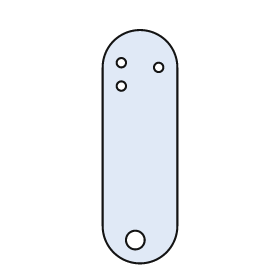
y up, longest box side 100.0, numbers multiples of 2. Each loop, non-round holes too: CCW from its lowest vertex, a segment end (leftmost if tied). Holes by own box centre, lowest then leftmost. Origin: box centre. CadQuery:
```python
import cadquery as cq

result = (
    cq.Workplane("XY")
    .moveTo(-16.0, -34.0)
    .threePointArc((0.0, -50.0), (16.0, -34.0))
    .lineTo(16.0, 34.0)
    .threePointArc((0.0, 50.0), (-16.0, 34.0))
    .close()
    .moveTo(-2.0, -40.0)
    .circle(4.0)
    .moveTo(-8.0, 26.0)
    .circle(2.0)
    .moveTo(8.0, 34.0)
    .circle(2.0)
    .moveTo(-8.0, 36.0)
    .circle(2.0)
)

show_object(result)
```